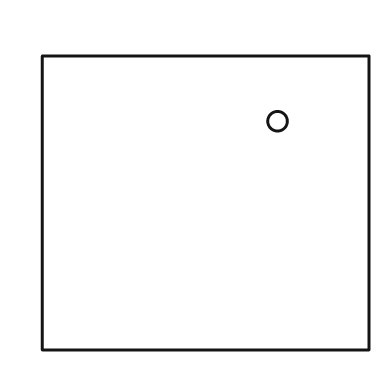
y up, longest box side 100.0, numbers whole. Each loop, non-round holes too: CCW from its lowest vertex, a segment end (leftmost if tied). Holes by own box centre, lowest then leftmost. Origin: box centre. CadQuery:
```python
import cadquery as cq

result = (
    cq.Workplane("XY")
    .moveTo(-50.0, -45.0)
    .lineTo(50.0, -45.0)
    .lineTo(50.0, 45.0)
    .lineTo(-50.0, 45.0)
    .close()
    .moveTo(22.0, 25.0)
    .circle(3.0)
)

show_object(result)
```